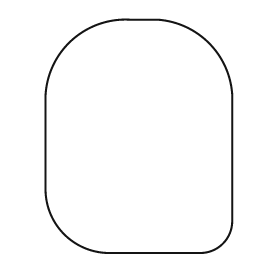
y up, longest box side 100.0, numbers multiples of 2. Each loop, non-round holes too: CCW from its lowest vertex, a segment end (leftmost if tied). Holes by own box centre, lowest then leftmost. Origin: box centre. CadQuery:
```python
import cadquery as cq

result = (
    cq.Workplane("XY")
    .moveTo(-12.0, -50.0)
    .lineTo(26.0, -50.0)
    .threePointArc((36.0, -46.0), (40.0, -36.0))
    .lineTo(40.0, 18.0)
    .threePointArc((30.0, 40.0), (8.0, 50.0))
    .lineTo(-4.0, 50.0)
    .threePointArc((-30.0, 40.0), (-40.0, 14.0))
    .lineTo(-40.0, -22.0)
    .threePointArc((-32.0, -42.0), (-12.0, -50.0))
    .close()
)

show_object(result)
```